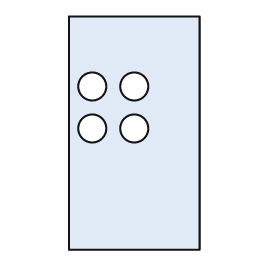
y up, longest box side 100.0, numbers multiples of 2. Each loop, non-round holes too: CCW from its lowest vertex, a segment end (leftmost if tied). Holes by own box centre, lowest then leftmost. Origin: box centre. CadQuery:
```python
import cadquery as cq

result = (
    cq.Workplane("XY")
    .moveTo(-28.0, -50.0)
    .lineTo(28.0, -50.0)
    .lineTo(28.0, 50.0)
    .lineTo(-28.0, 50.0)
    .close()
    .moveTo(-18.0, 2.0)
    .circle(6.0)
    .moveTo(0.0, 2.0)
    .circle(6.0)
    .moveTo(-18.0, 20.0)
    .circle(6.0)
    .moveTo(0.0, 20.0)
    .circle(6.0)
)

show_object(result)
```